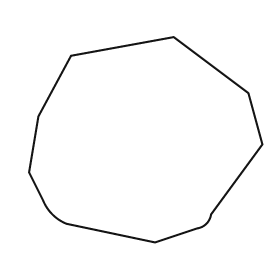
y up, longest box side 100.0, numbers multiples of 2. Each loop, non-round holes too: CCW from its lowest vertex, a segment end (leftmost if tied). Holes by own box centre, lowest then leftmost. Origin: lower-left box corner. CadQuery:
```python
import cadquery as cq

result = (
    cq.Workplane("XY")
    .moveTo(54.0, 0.0)
    .lineTo(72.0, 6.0)
    .threePointArc((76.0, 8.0), (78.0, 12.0))
    .lineTo(100.0, 42.0)
    .lineTo(94.0, 64.0)
    .lineTo(62.0, 88.0)
    .lineTo(18.0, 80.0)
    .lineTo(4.0, 54.0)
    .lineTo(0.0, 30.0)
    .lineTo(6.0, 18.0)
    .threePointArc((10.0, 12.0), (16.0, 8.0))
    .close()
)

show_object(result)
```